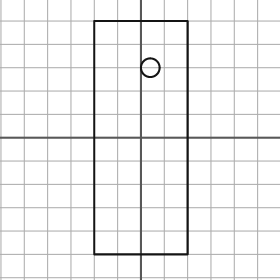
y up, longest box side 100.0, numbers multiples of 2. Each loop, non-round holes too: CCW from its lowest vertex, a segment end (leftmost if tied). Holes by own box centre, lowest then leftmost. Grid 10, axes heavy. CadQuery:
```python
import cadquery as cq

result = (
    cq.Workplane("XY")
    .moveTo(-20.0, -50.0)
    .lineTo(20.0, -50.0)
    .lineTo(20.0, 50.0)
    .lineTo(-20.0, 50.0)
    .close()
    .moveTo(4.0, 30.0)
    .circle(4.0)
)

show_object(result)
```